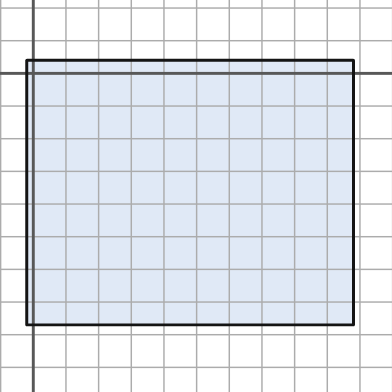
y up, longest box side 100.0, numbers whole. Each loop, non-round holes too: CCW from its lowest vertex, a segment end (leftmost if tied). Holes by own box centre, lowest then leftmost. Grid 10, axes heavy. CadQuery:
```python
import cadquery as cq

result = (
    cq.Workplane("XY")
    .moveTo(-2.0, -77.0)
    .lineTo(98.0, -77.0)
    .lineTo(98.0, 4.0)
    .lineTo(-2.0, 4.0)
    .close()
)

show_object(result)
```